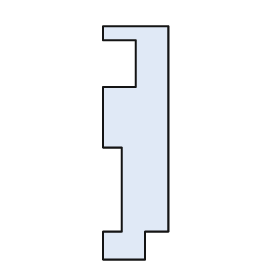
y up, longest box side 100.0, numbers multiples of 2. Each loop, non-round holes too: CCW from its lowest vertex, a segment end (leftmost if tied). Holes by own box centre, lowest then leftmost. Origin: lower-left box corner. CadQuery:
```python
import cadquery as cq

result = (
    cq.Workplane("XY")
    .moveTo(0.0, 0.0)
    .lineTo(18.0, 0.0)
    .lineTo(18.0, 12.0)
    .lineTo(28.0, 12.0)
    .lineTo(28.0, 100.0)
    .lineTo(0.0, 100.0)
    .lineTo(0.0, 94.0)
    .lineTo(14.0, 94.0)
    .lineTo(14.0, 74.0)
    .lineTo(0.0, 74.0)
    .lineTo(0.0, 48.0)
    .lineTo(8.0, 48.0)
    .lineTo(8.0, 12.0)
    .lineTo(0.0, 12.0)
    .close()
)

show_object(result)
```